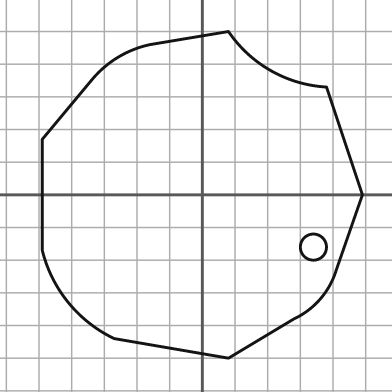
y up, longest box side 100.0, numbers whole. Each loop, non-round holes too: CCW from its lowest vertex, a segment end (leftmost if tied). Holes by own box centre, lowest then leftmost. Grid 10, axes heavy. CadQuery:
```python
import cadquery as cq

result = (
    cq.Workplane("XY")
    .moveTo(8.0, -50.0)
    .lineTo(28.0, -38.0)
    .threePointArc((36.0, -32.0), (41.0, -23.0))
    .lineTo(49.0, 0.0)
    .lineTo(38.0, 33.0)
    .threePointArc((21.0, 38.0), (8.0, 50.0))
    .lineTo(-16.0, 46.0)
    .threePointArc((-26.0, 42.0), (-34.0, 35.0))
    .lineTo(-49.0, 17.0)
    .lineTo(-49.0, -17.0)
    .threePointArc((-41.0, -33.0), (-27.0, -44.0))
    .close()
    .moveTo(34.0, -16.0)
    .circle(4.0)
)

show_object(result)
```